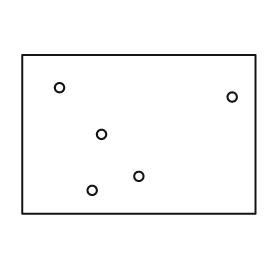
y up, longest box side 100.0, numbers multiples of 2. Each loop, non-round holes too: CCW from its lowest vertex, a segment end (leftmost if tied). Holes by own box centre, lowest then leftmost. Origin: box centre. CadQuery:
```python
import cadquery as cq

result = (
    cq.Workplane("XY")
    .moveTo(-50.0, -34.0)
    .lineTo(50.0, -34.0)
    .lineTo(50.0, 34.0)
    .lineTo(-50.0, 34.0)
    .close()
    .moveTo(-20.0, -24.0)
    .circle(2.0)
    .moveTo(0.0, -18.0)
    .circle(2.0)
    .moveTo(-16.0, 0.0)
    .circle(2.0)
    .moveTo(40.0, 16.0)
    .circle(2.0)
    .moveTo(-34.0, 20.0)
    .circle(2.0)
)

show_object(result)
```